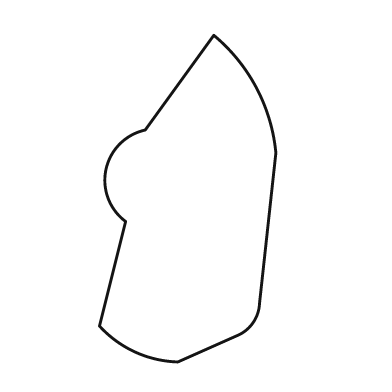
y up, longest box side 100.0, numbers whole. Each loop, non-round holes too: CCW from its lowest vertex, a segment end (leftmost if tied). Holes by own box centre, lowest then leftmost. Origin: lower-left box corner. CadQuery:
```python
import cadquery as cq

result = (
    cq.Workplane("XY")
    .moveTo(24.0, 0.0)
    .lineTo(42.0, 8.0)
    .threePointArc((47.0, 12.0), (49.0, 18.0))
    .lineTo(54.0, 64.0)
    .threePointArc((48.0, 84.0), (35.0, 100.0))
    .lineTo(14.0, 71.0)
    .threePointArc((2.0, 59.0), (8.0, 43.0))
    .lineTo(0.0, 11.0)
    .threePointArc((11.0, 3.0), (24.0, 0.0))
    .close()
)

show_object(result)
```